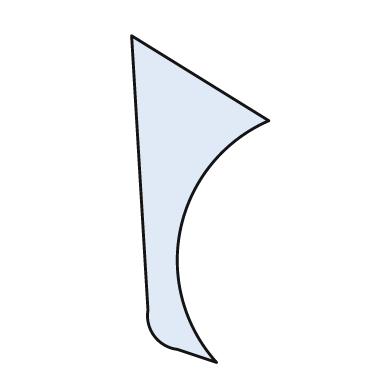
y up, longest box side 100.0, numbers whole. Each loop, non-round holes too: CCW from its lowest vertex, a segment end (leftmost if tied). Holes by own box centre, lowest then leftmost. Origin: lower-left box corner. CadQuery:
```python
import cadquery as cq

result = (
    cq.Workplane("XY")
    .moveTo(26.0, 0.0)
    .threePointArc((15.0, 41.0), (42.0, 74.0))
    .lineTo(0.0, 100.0)
    .lineTo(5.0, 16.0)
    .threePointArc((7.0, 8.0), (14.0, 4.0))
    .close()
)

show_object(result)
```